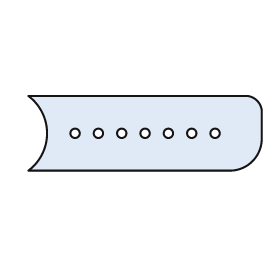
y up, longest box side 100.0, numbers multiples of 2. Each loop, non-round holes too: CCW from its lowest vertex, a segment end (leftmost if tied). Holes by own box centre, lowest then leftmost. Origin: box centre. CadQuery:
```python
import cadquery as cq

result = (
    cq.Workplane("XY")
    .moveTo(-50.0, -16.0)
    .lineTo(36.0, -16.0)
    .threePointArc((46.0, -12.0), (50.0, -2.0))
    .lineTo(50.0, 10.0)
    .threePointArc((48.0, 14.0), (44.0, 16.0))
    .lineTo(-50.0, 16.0)
    .threePointArc((-42.0, 0.0), (-50.0, -16.0))
    .close()
    .moveTo(-30.0, 0.0)
    .circle(2.0)
    .moveTo(-20.0, 0.0)
    .circle(2.0)
    .moveTo(-10.0, 0.0)
    .circle(2.0)
    .moveTo(0.0, 0.0)
    .circle(2.0)
    .moveTo(10.0, 0.0)
    .circle(2.0)
    .moveTo(20.0, 0.0)
    .circle(2.0)
    .moveTo(30.0, 0.0)
    .circle(2.0)
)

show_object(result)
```